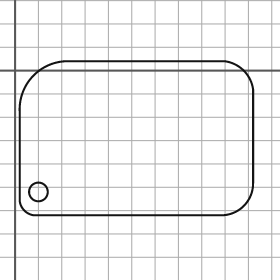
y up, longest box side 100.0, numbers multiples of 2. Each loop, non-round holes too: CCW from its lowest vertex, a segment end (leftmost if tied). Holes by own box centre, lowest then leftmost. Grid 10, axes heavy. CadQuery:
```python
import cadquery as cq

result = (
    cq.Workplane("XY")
    .moveTo(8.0, -62.0)
    .lineTo(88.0, -62.0)
    .threePointArc((98.0, -58.0), (102.0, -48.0))
    .lineTo(102.0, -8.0)
    .threePointArc((98.0, 0.0), (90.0, 4.0))
    .lineTo(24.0, 4.0)
    .threePointArc((8.0, -2.0), (2.0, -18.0))
    .lineTo(2.0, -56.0)
    .threePointArc((4.0, -60.0), (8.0, -62.0))
    .close()
    .moveTo(10.0, -52.0)
    .circle(4.0)
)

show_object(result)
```